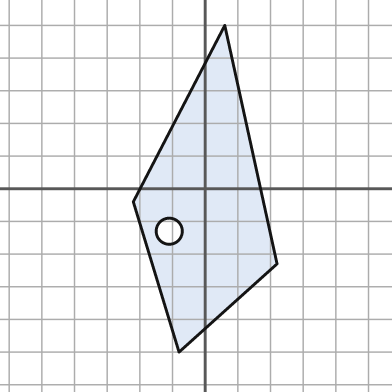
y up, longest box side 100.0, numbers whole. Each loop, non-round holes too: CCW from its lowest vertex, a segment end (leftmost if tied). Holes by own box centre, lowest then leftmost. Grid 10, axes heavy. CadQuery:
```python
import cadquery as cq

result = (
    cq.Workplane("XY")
    .moveTo(-8.0, -50.0)
    .lineTo(22.0, -23.0)
    .lineTo(6.0, 50.0)
    .lineTo(-22.0, -4.0)
    .close()
    .moveTo(-11.0, -13.0)
    .circle(4.0)
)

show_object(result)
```